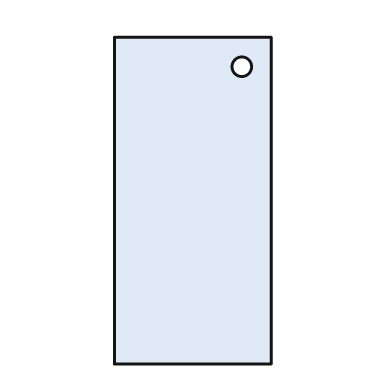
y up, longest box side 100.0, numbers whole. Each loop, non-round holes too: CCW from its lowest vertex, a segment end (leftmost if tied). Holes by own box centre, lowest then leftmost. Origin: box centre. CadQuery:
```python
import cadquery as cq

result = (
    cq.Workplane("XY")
    .moveTo(-24.0, -50.0)
    .lineTo(24.0, -50.0)
    .lineTo(24.0, 50.0)
    .lineTo(-24.0, 50.0)
    .close()
    .moveTo(15.0, 41.0)
    .circle(3.0)
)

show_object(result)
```